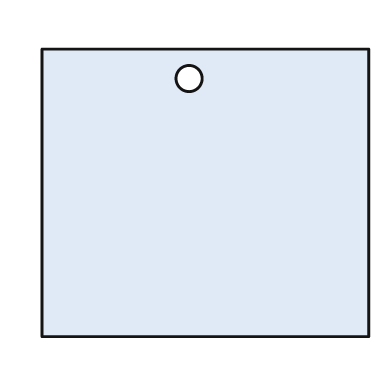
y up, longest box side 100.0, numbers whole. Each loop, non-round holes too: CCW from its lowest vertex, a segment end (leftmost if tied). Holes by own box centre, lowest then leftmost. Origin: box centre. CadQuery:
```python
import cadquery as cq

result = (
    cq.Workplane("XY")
    .moveTo(-50.0, -44.0)
    .lineTo(50.0, -44.0)
    .lineTo(50.0, 44.0)
    .lineTo(-50.0, 44.0)
    .close()
    .moveTo(-5.0, 35.0)
    .circle(4.0)
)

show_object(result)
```